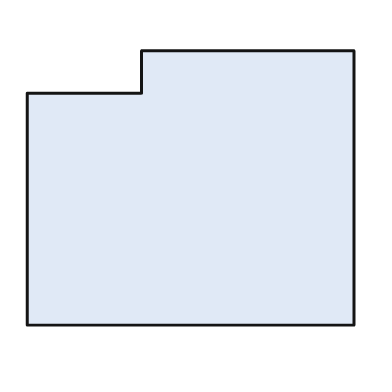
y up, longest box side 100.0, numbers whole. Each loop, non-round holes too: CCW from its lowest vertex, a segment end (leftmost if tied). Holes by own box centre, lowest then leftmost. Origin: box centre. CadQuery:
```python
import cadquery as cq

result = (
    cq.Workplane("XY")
    .moveTo(-50.0, -42.0)
    .lineTo(50.0, -42.0)
    .lineTo(50.0, 42.0)
    .lineTo(-15.0, 42.0)
    .lineTo(-15.0, 29.0)
    .lineTo(-50.0, 29.0)
    .close()
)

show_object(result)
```